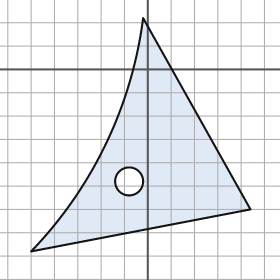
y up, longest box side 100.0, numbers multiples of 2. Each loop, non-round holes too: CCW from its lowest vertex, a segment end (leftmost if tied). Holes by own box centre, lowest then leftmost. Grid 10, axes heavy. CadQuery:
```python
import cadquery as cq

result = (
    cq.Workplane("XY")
    .moveTo(-50.0, -78.0)
    .lineTo(44.0, -60.0)
    .lineTo(-2.0, 22.0)
    .threePointArc((-18.0, -32.0), (-50.0, -78.0))
    .close()
    .moveTo(-8.0, -48.0)
    .circle(6.0)
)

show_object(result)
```